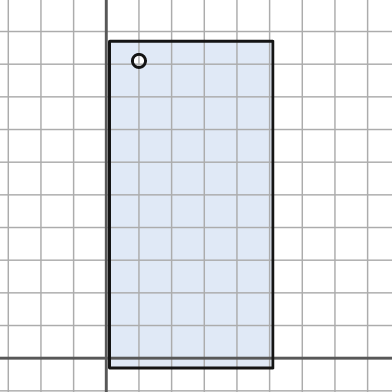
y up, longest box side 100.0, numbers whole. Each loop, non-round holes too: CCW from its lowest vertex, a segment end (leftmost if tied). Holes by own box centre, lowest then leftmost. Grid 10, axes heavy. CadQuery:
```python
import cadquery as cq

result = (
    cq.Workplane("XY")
    .moveTo(1.0, -3.0)
    .lineTo(51.0, -3.0)
    .lineTo(51.0, 97.0)
    .lineTo(1.0, 97.0)
    .close()
    .moveTo(10.0, 91.0)
    .circle(2.0)
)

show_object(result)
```